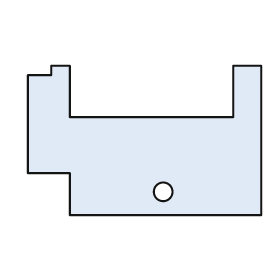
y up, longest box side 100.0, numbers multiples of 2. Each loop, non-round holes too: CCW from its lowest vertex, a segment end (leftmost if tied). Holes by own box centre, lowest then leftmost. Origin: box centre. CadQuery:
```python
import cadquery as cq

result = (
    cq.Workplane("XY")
    .moveTo(-32.0, -32.0)
    .lineTo(50.0, -32.0)
    .lineTo(50.0, 32.0)
    .lineTo(38.0, 32.0)
    .lineTo(38.0, 10.0)
    .lineTo(-32.0, 10.0)
    .lineTo(-32.0, 32.0)
    .lineTo(-40.0, 32.0)
    .lineTo(-40.0, 28.0)
    .lineTo(-50.0, 28.0)
    .lineTo(-50.0, -14.0)
    .lineTo(-32.0, -14.0)
    .close()
    .moveTo(8.0, -22.0)
    .circle(4.0)
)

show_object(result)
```